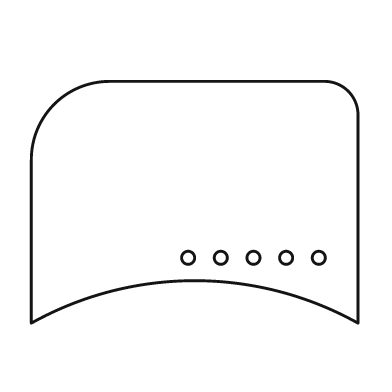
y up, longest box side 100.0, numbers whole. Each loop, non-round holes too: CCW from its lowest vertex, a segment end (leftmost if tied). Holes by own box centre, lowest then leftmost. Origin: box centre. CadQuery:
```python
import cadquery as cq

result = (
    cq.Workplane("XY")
    .moveTo(-50.0, -37.0)
    .threePointArc((0.0, -24.0), (50.0, -37.0))
    .lineTo(50.0, 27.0)
    .threePointArc((47.0, 34.0), (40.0, 37.0))
    .lineTo(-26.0, 37.0)
    .threePointArc((-43.0, 30.0), (-50.0, 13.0))
    .close()
    .moveTo(-2.0, -17.0)
    .circle(2.0)
    .moveTo(8.0, -17.0)
    .circle(2.0)
    .moveTo(18.0, -17.0)
    .circle(2.0)
    .moveTo(28.0, -17.0)
    .circle(2.0)
    .moveTo(38.0, -17.0)
    .circle(2.0)
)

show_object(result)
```